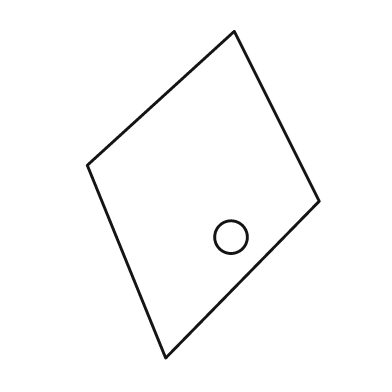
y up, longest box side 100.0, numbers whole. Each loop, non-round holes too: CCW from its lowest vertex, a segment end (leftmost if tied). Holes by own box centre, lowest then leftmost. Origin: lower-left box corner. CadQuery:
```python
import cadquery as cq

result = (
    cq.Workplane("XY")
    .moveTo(24.0, 0.0)
    .lineTo(71.0, 48.0)
    .lineTo(45.0, 100.0)
    .lineTo(0.0, 59.0)
    .close()
    .moveTo(44.0, 37.0)
    .circle(5.0)
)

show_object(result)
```